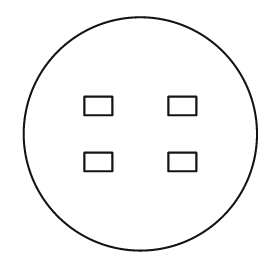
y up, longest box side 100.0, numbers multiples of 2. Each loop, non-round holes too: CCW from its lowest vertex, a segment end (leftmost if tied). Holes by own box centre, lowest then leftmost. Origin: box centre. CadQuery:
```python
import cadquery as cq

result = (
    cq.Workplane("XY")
    .moveTo(0.0, 0.0)
    .circle(50.0)
    .moveTo(-24.0, -16.0)
    .lineTo(-12.0, -16.0)
    .lineTo(-12.0, -8.0)
    .lineTo(-24.0, -8.0)
    .close()
    .moveTo(12.0, -16.0)
    .lineTo(24.0, -16.0)
    .lineTo(24.0, -8.0)
    .lineTo(12.0, -8.0)
    .close()
    .moveTo(-24.0, 8.0)
    .lineTo(-12.0, 8.0)
    .lineTo(-12.0, 16.0)
    .lineTo(-24.0, 16.0)
    .close()
    .moveTo(12.0, 8.0)
    .lineTo(24.0, 8.0)
    .lineTo(24.0, 16.0)
    .lineTo(12.0, 16.0)
    .close()
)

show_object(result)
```